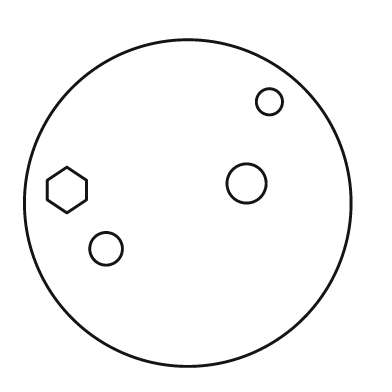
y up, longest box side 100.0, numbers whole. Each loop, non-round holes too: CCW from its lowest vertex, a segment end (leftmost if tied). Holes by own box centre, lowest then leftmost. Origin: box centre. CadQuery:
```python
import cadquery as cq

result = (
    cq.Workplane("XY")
    .moveTo(0.0, 0.0)
    .circle(50.0)
    .moveTo(-25.0, -14.0)
    .circle(5.0)
    .moveTo(-37.0, -3.0)
    .lineTo(-31.0, 1.0)
    .lineTo(-31.0, 7.0)
    .lineTo(-37.0, 11.0)
    .lineTo(-43.0, 7.0)
    .lineTo(-43.0, 1.0)
    .close()
    .moveTo(18.0, 6.0)
    .circle(6.0)
    .moveTo(25.0, 31.0)
    .circle(4.0)
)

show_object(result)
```